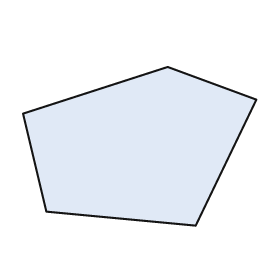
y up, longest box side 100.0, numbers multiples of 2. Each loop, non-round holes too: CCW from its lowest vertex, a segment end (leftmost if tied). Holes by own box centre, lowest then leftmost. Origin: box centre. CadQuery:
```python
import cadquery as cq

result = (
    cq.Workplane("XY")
    .moveTo(24.0, -34.0)
    .lineTo(50.0, 20.0)
    .lineTo(12.0, 34.0)
    .lineTo(-50.0, 14.0)
    .lineTo(-40.0, -28.0)
    .close()
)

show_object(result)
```